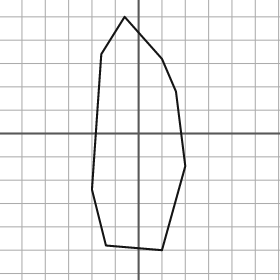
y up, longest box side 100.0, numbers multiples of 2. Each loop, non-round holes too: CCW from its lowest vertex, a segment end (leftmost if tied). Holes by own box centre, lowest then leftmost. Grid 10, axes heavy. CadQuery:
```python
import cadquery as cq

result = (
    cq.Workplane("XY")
    .moveTo(10.0, -50.0)
    .lineTo(20.0, -14.0)
    .lineTo(16.0, 18.0)
    .lineTo(10.0, 32.0)
    .lineTo(-6.0, 50.0)
    .lineTo(-16.0, 34.0)
    .lineTo(-20.0, -24.0)
    .lineTo(-14.0, -48.0)
    .close()
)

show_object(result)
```